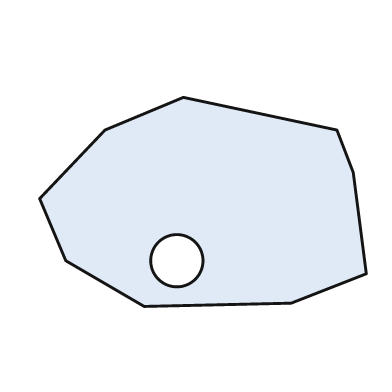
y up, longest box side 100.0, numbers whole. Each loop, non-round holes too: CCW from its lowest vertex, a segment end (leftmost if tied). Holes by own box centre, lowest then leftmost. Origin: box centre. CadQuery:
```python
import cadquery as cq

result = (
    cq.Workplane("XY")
    .moveTo(-18.0, -32.0)
    .lineTo(27.0, -31.0)
    .lineTo(50.0, -22.0)
    .lineTo(46.0, 9.0)
    .lineTo(41.0, 22.0)
    .lineTo(-6.0, 32.0)
    .lineTo(-30.0, 22.0)
    .lineTo(-50.0, 1.0)
    .lineTo(-42.0, -18.0)
    .close()
    .moveTo(-8.0, -18.0)
    .circle(8.0)
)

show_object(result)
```